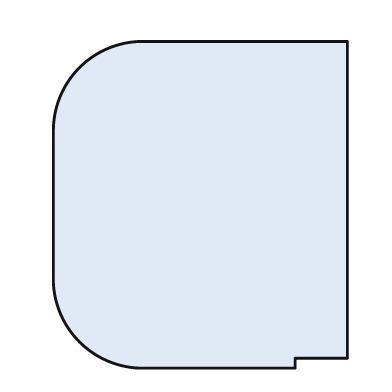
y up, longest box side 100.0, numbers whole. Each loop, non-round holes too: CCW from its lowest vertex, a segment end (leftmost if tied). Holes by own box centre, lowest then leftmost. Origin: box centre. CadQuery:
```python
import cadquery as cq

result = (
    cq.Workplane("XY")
    .moveTo(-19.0, -50.0)
    .lineTo(29.0, -50.0)
    .lineTo(29.0, -47.0)
    .lineTo(45.0, -47.0)
    .lineTo(45.0, 50.0)
    .lineTo(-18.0, 50.0)
    .threePointArc((-37.0, 42.0), (-45.0, 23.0))
    .lineTo(-45.0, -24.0)
    .threePointArc((-37.0, -42.0), (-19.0, -50.0))
    .close()
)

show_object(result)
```